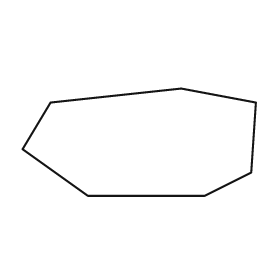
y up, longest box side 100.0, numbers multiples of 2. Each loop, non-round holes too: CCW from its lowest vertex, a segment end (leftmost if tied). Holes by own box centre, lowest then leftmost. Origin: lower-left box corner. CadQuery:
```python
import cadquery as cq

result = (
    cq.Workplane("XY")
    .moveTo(28.0, 0.0)
    .lineTo(78.0, 0.0)
    .lineTo(98.0, 10.0)
    .lineTo(100.0, 40.0)
    .lineTo(68.0, 46.0)
    .lineTo(12.0, 40.0)
    .lineTo(0.0, 20.0)
    .close()
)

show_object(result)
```